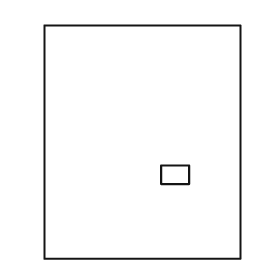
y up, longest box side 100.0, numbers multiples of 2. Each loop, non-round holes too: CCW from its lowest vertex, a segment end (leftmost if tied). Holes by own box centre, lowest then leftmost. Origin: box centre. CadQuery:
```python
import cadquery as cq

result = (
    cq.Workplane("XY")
    .moveTo(-42.0, -50.0)
    .lineTo(42.0, -50.0)
    .lineTo(42.0, 50.0)
    .lineTo(-42.0, 50.0)
    .close()
    .moveTo(8.0, -18.0)
    .lineTo(20.0, -18.0)
    .lineTo(20.0, -10.0)
    .lineTo(8.0, -10.0)
    .close()
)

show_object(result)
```